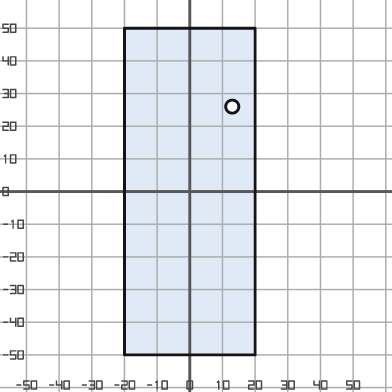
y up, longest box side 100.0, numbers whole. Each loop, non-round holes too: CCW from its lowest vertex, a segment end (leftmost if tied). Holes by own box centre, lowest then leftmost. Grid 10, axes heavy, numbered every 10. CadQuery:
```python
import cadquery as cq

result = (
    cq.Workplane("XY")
    .moveTo(-20.0, -50.0)
    .lineTo(20.0, -50.0)
    .lineTo(20.0, 50.0)
    .lineTo(-20.0, 50.0)
    .close()
    .moveTo(13.0, 26.0)
    .circle(2.0)
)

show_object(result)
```